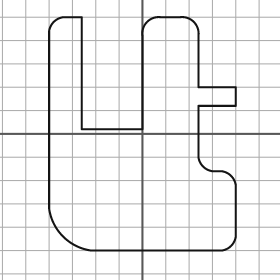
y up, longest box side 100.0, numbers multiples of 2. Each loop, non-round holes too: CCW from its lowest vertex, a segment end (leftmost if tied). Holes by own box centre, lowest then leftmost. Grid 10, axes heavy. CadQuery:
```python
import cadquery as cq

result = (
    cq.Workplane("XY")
    .moveTo(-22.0, -50.0)
    .lineTo(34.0, -50.0)
    .threePointArc((38.0, -48.0), (40.0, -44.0))
    .lineTo(40.0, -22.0)
    .threePointArc((38.0, -18.0), (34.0, -16.0))
    .lineTo(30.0, -16.0)
    .threePointArc((26.0, -14.0), (24.0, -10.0))
    .lineTo(24.0, 12.0)
    .lineTo(40.0, 12.0)
    .lineTo(40.0, 20.0)
    .lineTo(24.0, 20.0)
    .lineTo(24.0, 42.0)
    .threePointArc((22.0, 48.0), (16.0, 50.0))
    .lineTo(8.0, 50.0)
    .threePointArc((2.0, 48.0), (0.0, 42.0))
    .lineTo(0.0, 2.0)
    .lineTo(-26.0, 2.0)
    .lineTo(-26.0, 50.0)
    .lineTo(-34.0, 50.0)
    .threePointArc((-38.0, 48.0), (-40.0, 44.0))
    .lineTo(-40.0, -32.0)
    .threePointArc((-34.0, -44.0), (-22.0, -50.0))
    .close()
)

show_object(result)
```